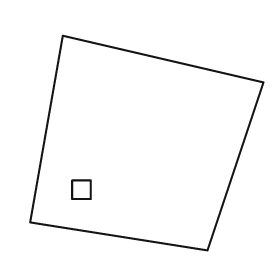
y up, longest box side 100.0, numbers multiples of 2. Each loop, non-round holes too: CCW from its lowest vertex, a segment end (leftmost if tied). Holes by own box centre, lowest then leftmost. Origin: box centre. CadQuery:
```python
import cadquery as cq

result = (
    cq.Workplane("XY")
    .moveTo(26.0, -46.0)
    .lineTo(50.0, 26.0)
    .lineTo(-36.0, 46.0)
    .lineTo(-50.0, -34.0)
    .close()
    .moveTo(-32.0, -24.0)
    .lineTo(-24.0, -24.0)
    .lineTo(-24.0, -16.0)
    .lineTo(-32.0, -16.0)
    .close()
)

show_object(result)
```